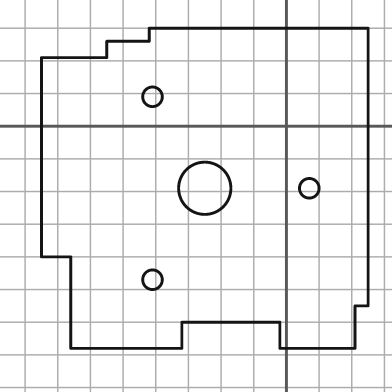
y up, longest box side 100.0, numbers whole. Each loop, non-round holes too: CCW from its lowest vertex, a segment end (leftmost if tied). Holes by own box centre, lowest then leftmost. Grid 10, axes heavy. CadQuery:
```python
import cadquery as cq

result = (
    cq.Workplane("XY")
    .moveTo(-66.0, -68.0)
    .lineTo(-32.0, -68.0)
    .lineTo(-32.0, -60.0)
    .lineTo(-2.0, -60.0)
    .lineTo(-2.0, -68.0)
    .lineTo(21.0, -68.0)
    .lineTo(21.0, -55.0)
    .lineTo(25.0, -55.0)
    .lineTo(25.0, 30.0)
    .lineTo(-42.0, 30.0)
    .lineTo(-42.0, 26.0)
    .lineTo(-55.0, 26.0)
    .lineTo(-55.0, 21.0)
    .lineTo(-75.0, 21.0)
    .lineTo(-75.0, -40.0)
    .lineTo(-66.0, -40.0)
    .close()
    .moveTo(-41.0, -47.0)
    .circle(3.0)
    .moveTo(-25.0, -19.0)
    .circle(8.0)
    .moveTo(7.0, -19.0)
    .circle(3.0)
    .moveTo(-41.0, 9.0)
    .circle(3.0)
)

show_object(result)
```